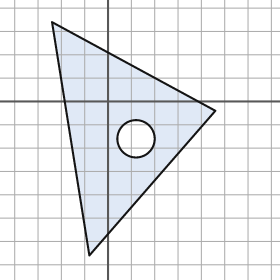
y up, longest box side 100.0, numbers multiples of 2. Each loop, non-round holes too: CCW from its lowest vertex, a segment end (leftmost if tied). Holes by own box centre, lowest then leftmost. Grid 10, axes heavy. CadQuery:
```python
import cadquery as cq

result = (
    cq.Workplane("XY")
    .moveTo(-8.0, -66.0)
    .lineTo(46.0, -4.0)
    .lineTo(-24.0, 34.0)
    .close()
    .moveTo(12.0, -16.0)
    .circle(8.0)
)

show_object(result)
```